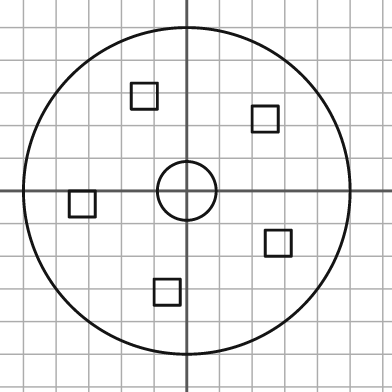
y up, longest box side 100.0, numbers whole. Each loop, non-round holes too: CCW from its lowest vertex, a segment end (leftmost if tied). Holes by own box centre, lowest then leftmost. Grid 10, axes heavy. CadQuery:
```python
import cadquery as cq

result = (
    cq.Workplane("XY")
    .moveTo(0.0, 0.0)
    .circle(50.0)
    .moveTo(-10.0, -35.0)
    .lineTo(-2.0, -35.0)
    .lineTo(-2.0, -27.0)
    .lineTo(-10.0, -27.0)
    .close()
    .moveTo(24.0, -20.0)
    .lineTo(32.0, -20.0)
    .lineTo(32.0, -12.0)
    .lineTo(24.0, -12.0)
    .close()
    .moveTo(-36.0, -8.0)
    .lineTo(-28.0, -8.0)
    .lineTo(-28.0, 0.0)
    .lineTo(-36.0, 0.0)
    .close()
    .moveTo(0.0, 0.0)
    .circle(9.0)
    .moveTo(20.0, 18.0)
    .lineTo(28.0, 18.0)
    .lineTo(28.0, 26.0)
    .lineTo(20.0, 26.0)
    .close()
    .moveTo(-17.0, 25.0)
    .lineTo(-9.0, 25.0)
    .lineTo(-9.0, 33.0)
    .lineTo(-17.0, 33.0)
    .close()
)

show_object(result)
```